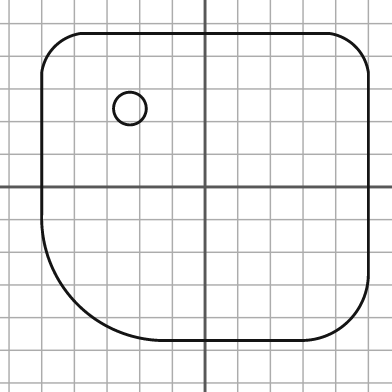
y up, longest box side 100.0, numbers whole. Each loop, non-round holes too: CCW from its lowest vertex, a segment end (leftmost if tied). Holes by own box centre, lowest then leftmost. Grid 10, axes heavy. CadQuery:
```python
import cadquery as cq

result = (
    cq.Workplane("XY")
    .moveTo(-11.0, -47.0)
    .lineTo(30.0, -47.0)
    .threePointArc((44.0, -41.0), (50.0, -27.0))
    .lineTo(50.0, 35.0)
    .threePointArc((46.0, 43.0), (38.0, 47.0))
    .lineTo(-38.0, 47.0)
    .threePointArc((-46.0, 43.0), (-50.0, 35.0))
    .lineTo(-50.0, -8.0)
    .threePointArc((-39.0, -36.0), (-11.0, -47.0))
    .close()
    .moveTo(-23.0, 24.0)
    .circle(5.0)
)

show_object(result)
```